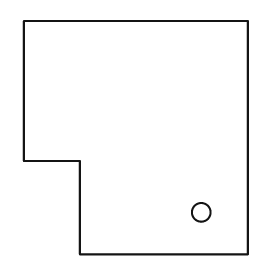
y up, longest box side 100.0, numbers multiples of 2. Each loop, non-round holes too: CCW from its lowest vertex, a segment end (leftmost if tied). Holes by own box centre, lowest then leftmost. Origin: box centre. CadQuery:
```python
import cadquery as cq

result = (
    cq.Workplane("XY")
    .moveTo(-24.0, -50.0)
    .lineTo(48.0, -50.0)
    .lineTo(48.0, 50.0)
    .lineTo(-48.0, 50.0)
    .lineTo(-48.0, -10.0)
    .lineTo(-24.0, -10.0)
    .close()
    .moveTo(28.0, -32.0)
    .circle(4.0)
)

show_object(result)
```